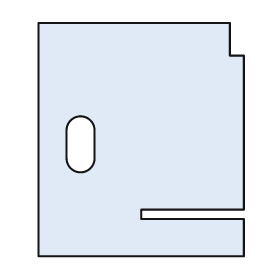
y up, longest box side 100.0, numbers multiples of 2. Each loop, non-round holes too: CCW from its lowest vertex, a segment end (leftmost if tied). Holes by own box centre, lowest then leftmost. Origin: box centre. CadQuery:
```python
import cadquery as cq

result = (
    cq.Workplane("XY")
    .moveTo(-44.0, -50.0)
    .lineTo(44.0, -50.0)
    .lineTo(44.0, -34.0)
    .lineTo(0.0, -34.0)
    .lineTo(0.0, -30.0)
    .lineTo(44.0, -30.0)
    .lineTo(44.0, 36.0)
    .lineTo(38.0, 36.0)
    .lineTo(38.0, 50.0)
    .lineTo(-44.0, 50.0)
    .close()
    .moveTo(-32.0, -8.0)
    .threePointArc((-26.0, -14.0), (-20.0, -8.0))
    .lineTo(-20.0, 4.0)
    .threePointArc((-26.0, 10.0), (-32.0, 4.0))
    .close()
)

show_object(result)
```